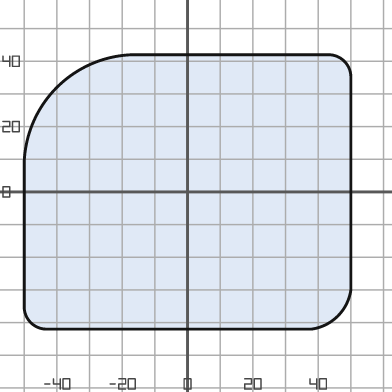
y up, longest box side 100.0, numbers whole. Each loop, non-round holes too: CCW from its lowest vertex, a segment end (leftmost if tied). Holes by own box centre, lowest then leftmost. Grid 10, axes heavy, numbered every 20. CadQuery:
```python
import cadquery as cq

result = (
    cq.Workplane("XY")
    .moveTo(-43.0, -42.0)
    .lineTo(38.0, -42.0)
    .threePointArc((46.0, -38.0), (50.0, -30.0))
    .lineTo(50.0, 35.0)
    .threePointArc((48.0, 40.0), (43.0, 42.0))
    .lineTo(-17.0, 42.0)
    .threePointArc((-40.0, 32.0), (-50.0, 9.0))
    .lineTo(-50.0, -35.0)
    .threePointArc((-48.0, -40.0), (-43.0, -42.0))
    .close()
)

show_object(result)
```